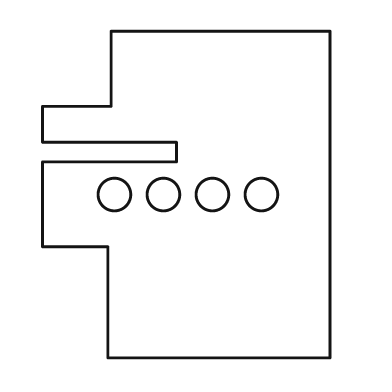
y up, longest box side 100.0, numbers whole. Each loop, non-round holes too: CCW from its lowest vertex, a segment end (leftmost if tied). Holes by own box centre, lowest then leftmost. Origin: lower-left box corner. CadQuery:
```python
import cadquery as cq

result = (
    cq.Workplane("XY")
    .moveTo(20.0, 0.0)
    .lineTo(88.0, 0.0)
    .lineTo(88.0, 100.0)
    .lineTo(21.0, 100.0)
    .lineTo(21.0, 77.0)
    .lineTo(0.0, 77.0)
    .lineTo(0.0, 66.0)
    .lineTo(41.0, 66.0)
    .lineTo(41.0, 60.0)
    .lineTo(0.0, 60.0)
    .lineTo(0.0, 34.0)
    .lineTo(20.0, 34.0)
    .close()
    .moveTo(22.0, 50.0)
    .circle(5.0)
    .moveTo(37.0, 50.0)
    .circle(5.0)
    .moveTo(52.0, 50.0)
    .circle(5.0)
    .moveTo(67.0, 50.0)
    .circle(5.0)
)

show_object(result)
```